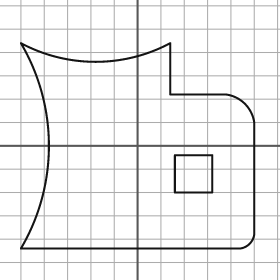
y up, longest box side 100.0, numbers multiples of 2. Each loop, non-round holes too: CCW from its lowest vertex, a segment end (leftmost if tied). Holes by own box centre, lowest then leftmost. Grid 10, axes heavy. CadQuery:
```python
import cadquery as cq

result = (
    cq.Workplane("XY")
    .moveTo(-50.0, -44.0)
    .lineTo(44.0, -44.0)
    .threePointArc((48.0, -42.0), (50.0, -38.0))
    .lineTo(50.0, 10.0)
    .threePointArc((46.0, 18.0), (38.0, 22.0))
    .lineTo(14.0, 22.0)
    .lineTo(14.0, 44.0)
    .threePointArc((-18.0, 36.0), (-50.0, 44.0))
    .threePointArc((-38.0, 0.0), (-50.0, -44.0))
    .close()
    .moveTo(16.0, -20.0)
    .lineTo(32.0, -20.0)
    .lineTo(32.0, -4.0)
    .lineTo(16.0, -4.0)
    .close()
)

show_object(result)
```